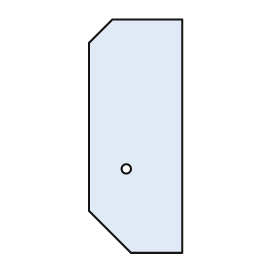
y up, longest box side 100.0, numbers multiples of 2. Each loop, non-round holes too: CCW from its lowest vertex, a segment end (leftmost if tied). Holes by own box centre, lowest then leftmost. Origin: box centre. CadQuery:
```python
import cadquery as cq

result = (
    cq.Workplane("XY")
    .moveTo(-2.0, -50.0)
    .lineTo(20.0, -50.0)
    .lineTo(20.0, 50.0)
    .lineTo(-10.0, 50.0)
    .lineTo(-20.0, 40.0)
    .lineTo(-20.0, -32.0)
    .close()
    .moveTo(-4.0, -14.0)
    .circle(2.0)
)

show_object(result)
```